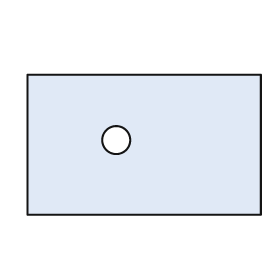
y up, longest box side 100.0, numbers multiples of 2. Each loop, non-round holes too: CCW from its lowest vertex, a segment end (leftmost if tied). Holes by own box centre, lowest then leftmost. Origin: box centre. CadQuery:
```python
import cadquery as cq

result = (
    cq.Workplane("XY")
    .moveTo(-50.0, -30.0)
    .lineTo(50.0, -30.0)
    .lineTo(50.0, 30.0)
    .lineTo(-50.0, 30.0)
    .close()
    .moveTo(-12.0, 2.0)
    .circle(6.0)
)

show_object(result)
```